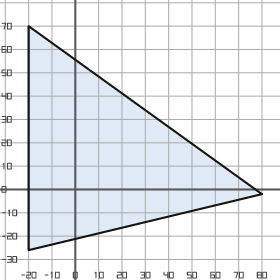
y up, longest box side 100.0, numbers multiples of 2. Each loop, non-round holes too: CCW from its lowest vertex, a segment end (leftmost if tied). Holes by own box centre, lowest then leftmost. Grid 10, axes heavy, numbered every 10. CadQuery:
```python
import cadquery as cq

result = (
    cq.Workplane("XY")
    .moveTo(-20.0, -26.0)
    .lineTo(80.0, -2.0)
    .lineTo(-20.0, 70.0)
    .close()
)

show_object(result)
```